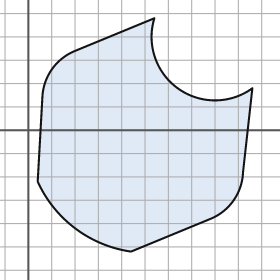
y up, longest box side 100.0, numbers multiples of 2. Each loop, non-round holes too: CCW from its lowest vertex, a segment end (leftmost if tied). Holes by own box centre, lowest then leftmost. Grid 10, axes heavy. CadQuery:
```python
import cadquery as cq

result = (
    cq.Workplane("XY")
    .moveTo(44.0, -52.0)
    .lineTo(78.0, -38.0)
    .threePointArc((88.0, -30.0), (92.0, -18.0))
    .lineTo(96.0, 18.0)
    .threePointArc((64.0, 18.0), (54.0, 48.0))
    .lineTo(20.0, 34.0)
    .threePointArc((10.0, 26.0), (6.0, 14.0))
    .lineTo(4.0, -22.0)
    .threePointArc((20.0, -42.0), (44.0, -52.0))
    .close()
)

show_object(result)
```